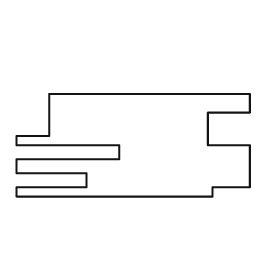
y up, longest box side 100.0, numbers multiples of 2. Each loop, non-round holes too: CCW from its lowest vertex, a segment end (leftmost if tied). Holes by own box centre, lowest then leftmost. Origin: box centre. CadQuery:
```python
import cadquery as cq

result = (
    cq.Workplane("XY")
    .moveTo(-50.0, -22.0)
    .lineTo(34.0, -22.0)
    .lineTo(34.0, -18.0)
    .lineTo(50.0, -18.0)
    .lineTo(50.0, 0.0)
    .lineTo(32.0, 0.0)
    .lineTo(32.0, 14.0)
    .lineTo(50.0, 14.0)
    .lineTo(50.0, 22.0)
    .lineTo(-36.0, 22.0)
    .lineTo(-36.0, 4.0)
    .lineTo(-50.0, 4.0)
    .lineTo(-50.0, 0.0)
    .lineTo(-6.0, 0.0)
    .lineTo(-6.0, -6.0)
    .lineTo(-50.0, -6.0)
    .lineTo(-50.0, -12.0)
    .lineTo(-20.0, -12.0)
    .lineTo(-20.0, -18.0)
    .lineTo(-50.0, -18.0)
    .close()
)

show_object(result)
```